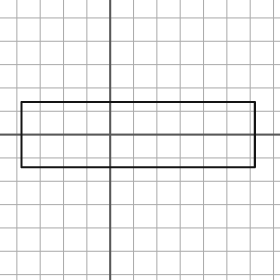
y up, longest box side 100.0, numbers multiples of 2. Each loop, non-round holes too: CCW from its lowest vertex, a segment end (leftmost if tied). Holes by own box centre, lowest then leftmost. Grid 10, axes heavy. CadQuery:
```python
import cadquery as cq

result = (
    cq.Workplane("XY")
    .moveTo(-38.0, -14.0)
    .lineTo(62.0, -14.0)
    .lineTo(62.0, 14.0)
    .lineTo(-38.0, 14.0)
    .close()
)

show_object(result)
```